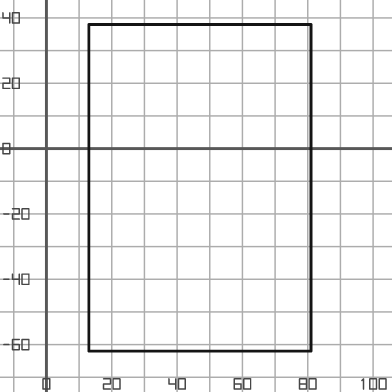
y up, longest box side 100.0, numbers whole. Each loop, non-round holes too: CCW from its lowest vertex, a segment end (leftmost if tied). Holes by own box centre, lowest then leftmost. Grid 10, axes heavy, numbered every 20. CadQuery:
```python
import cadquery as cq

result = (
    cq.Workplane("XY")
    .moveTo(13.0, -62.0)
    .lineTo(81.0, -62.0)
    .lineTo(81.0, 38.0)
    .lineTo(13.0, 38.0)
    .close()
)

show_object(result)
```